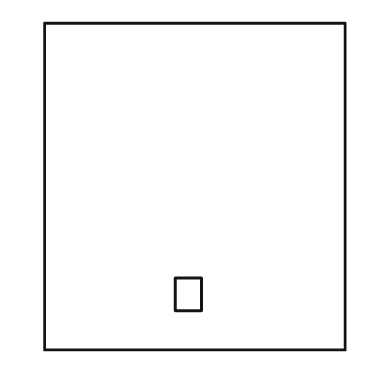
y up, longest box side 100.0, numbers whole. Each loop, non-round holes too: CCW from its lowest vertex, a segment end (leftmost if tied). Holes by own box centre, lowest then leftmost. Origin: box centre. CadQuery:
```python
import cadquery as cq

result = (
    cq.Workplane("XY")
    .moveTo(-46.0, -50.0)
    .lineTo(46.0, -50.0)
    .lineTo(46.0, 50.0)
    .lineTo(-46.0, 50.0)
    .close()
    .moveTo(-6.0, -38.0)
    .lineTo(2.0, -38.0)
    .lineTo(2.0, -28.0)
    .lineTo(-6.0, -28.0)
    .close()
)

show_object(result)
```